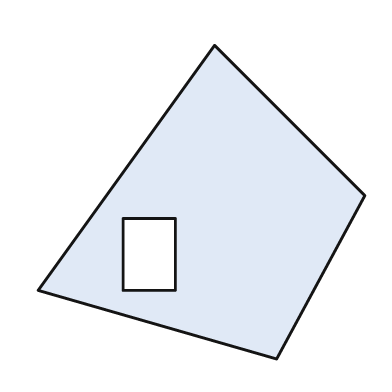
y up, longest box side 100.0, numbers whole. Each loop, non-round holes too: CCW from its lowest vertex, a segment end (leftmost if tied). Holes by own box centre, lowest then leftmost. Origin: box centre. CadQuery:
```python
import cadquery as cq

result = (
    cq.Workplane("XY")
    .moveTo(23.0, -48.0)
    .lineTo(50.0, 2.0)
    .lineTo(4.0, 48.0)
    .lineTo(-50.0, -27.0)
    .close()
    .moveTo(-24.0, -27.0)
    .lineTo(-8.0, -27.0)
    .lineTo(-8.0, -5.0)
    .lineTo(-24.0, -5.0)
    .close()
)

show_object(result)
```